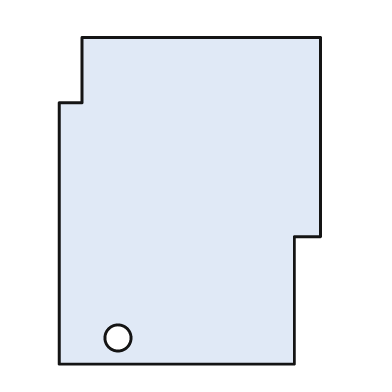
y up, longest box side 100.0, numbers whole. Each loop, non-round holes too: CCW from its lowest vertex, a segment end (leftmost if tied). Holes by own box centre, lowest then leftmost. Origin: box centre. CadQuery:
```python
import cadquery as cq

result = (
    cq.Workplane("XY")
    .moveTo(-40.0, -50.0)
    .lineTo(32.0, -50.0)
    .lineTo(32.0, -11.0)
    .lineTo(40.0, -11.0)
    .lineTo(40.0, 50.0)
    .lineTo(-33.0, 50.0)
    .lineTo(-33.0, 30.0)
    .lineTo(-40.0, 30.0)
    .close()
    .moveTo(-22.0, -42.0)
    .circle(4.0)
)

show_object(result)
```